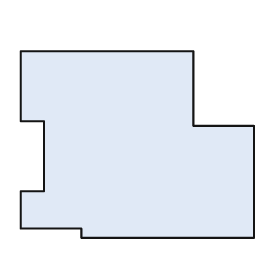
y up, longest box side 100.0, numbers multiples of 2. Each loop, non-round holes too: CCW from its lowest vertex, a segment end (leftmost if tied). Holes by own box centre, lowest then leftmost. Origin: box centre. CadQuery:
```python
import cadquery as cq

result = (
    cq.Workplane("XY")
    .moveTo(-24.0, -40.0)
    .lineTo(50.0, -40.0)
    .lineTo(50.0, 8.0)
    .lineTo(24.0, 8.0)
    .lineTo(24.0, 40.0)
    .lineTo(-50.0, 40.0)
    .lineTo(-50.0, 10.0)
    .lineTo(-40.0, 10.0)
    .lineTo(-40.0, -20.0)
    .lineTo(-50.0, -20.0)
    .lineTo(-50.0, -36.0)
    .lineTo(-24.0, -36.0)
    .close()
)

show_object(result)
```